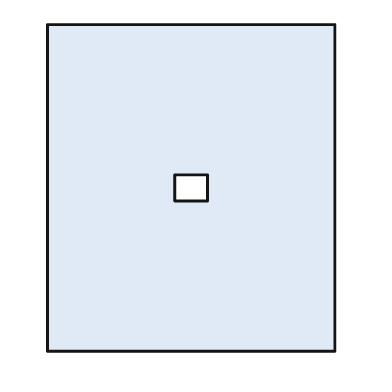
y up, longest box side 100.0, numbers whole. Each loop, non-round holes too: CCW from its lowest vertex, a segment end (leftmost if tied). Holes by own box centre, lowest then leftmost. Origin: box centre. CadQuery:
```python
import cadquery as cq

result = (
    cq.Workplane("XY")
    .moveTo(-44.0, -50.0)
    .lineTo(44.0, -50.0)
    .lineTo(44.0, 50.0)
    .lineTo(-44.0, 50.0)
    .close()
    .moveTo(-5.0, -4.0)
    .lineTo(5.0, -4.0)
    .lineTo(5.0, 4.0)
    .lineTo(-5.0, 4.0)
    .close()
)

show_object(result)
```